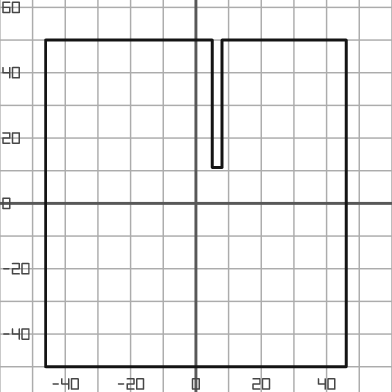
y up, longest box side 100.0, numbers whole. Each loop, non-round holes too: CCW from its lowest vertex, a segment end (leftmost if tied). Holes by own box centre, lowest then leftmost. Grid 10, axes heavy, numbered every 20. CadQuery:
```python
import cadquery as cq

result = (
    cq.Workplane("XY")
    .moveTo(-46.0, -50.0)
    .lineTo(46.0, -50.0)
    .lineTo(46.0, 50.0)
    .lineTo(8.0, 50.0)
    .lineTo(8.0, 11.0)
    .lineTo(5.0, 11.0)
    .lineTo(5.0, 50.0)
    .lineTo(-46.0, 50.0)
    .close()
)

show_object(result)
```